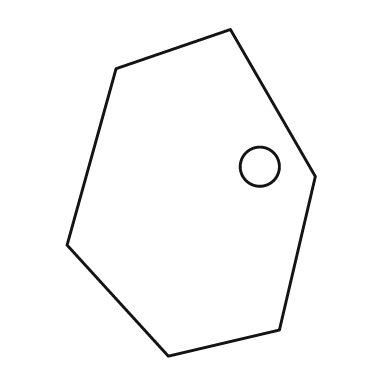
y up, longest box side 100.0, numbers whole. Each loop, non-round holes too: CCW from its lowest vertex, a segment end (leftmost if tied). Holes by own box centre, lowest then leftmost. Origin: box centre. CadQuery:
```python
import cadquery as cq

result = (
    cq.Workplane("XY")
    .moveTo(-7.0, -50.0)
    .lineTo(27.0, -42.0)
    .lineTo(38.0, 5.0)
    .lineTo(12.0, 50.0)
    .lineTo(-23.0, 38.0)
    .lineTo(-38.0, -16.0)
    .close()
    .moveTo(21.0, 8.0)
    .circle(6.0)
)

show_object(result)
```